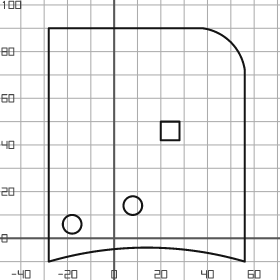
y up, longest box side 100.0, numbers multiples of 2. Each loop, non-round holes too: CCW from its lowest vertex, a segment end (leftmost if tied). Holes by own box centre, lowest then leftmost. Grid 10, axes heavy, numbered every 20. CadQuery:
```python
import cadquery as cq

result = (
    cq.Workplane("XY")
    .moveTo(-28.0, -10.0)
    .threePointArc((14.0, -4.0), (56.0, -10.0))
    .lineTo(56.0, 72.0)
    .threePointArc((50.0, 84.0), (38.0, 90.0))
    .lineTo(-28.0, 90.0)
    .close()
    .moveTo(-18.0, 6.0)
    .circle(4.0)
    .moveTo(8.0, 14.0)
    .circle(4.0)
    .moveTo(20.0, 42.0)
    .lineTo(28.0, 42.0)
    .lineTo(28.0, 50.0)
    .lineTo(20.0, 50.0)
    .close()
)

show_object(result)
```